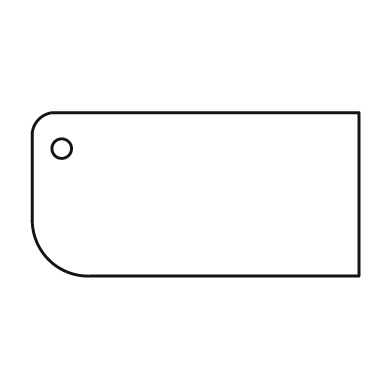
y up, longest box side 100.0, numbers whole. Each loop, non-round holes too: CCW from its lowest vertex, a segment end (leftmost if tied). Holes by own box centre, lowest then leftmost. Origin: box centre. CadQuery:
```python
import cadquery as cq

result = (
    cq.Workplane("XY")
    .moveTo(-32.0, -25.0)
    .lineTo(50.0, -25.0)
    .lineTo(50.0, 25.0)
    .lineTo(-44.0, 25.0)
    .threePointArc((-48.0, 23.0), (-50.0, 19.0))
    .lineTo(-50.0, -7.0)
    .threePointArc((-45.0, -20.0), (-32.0, -25.0))
    .close()
    .moveTo(-41.0, 14.0)
    .circle(3.0)
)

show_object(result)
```